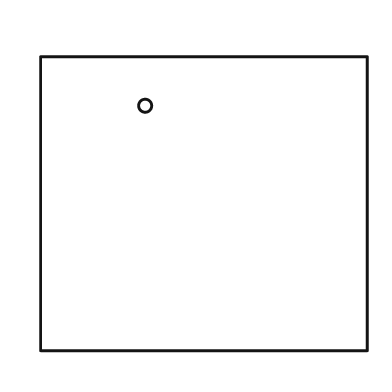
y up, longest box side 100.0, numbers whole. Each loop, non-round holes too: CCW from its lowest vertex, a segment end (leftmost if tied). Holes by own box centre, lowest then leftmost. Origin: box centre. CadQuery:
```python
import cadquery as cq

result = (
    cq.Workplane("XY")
    .moveTo(-50.0, -45.0)
    .lineTo(50.0, -45.0)
    .lineTo(50.0, 45.0)
    .lineTo(-50.0, 45.0)
    .close()
    .moveTo(-18.0, 30.0)
    .circle(2.0)
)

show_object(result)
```